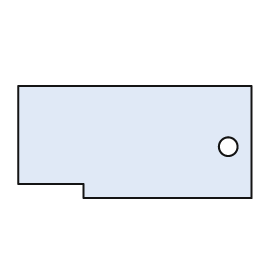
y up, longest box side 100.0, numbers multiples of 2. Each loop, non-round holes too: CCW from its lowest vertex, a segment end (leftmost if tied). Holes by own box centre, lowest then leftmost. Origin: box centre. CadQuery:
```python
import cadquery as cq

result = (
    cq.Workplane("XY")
    .moveTo(-22.0, -24.0)
    .lineTo(50.0, -24.0)
    .lineTo(50.0, 24.0)
    .lineTo(-50.0, 24.0)
    .lineTo(-50.0, -18.0)
    .lineTo(-22.0, -18.0)
    .close()
    .moveTo(40.0, -2.0)
    .circle(4.0)
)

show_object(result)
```